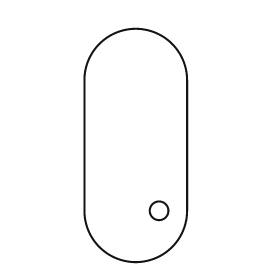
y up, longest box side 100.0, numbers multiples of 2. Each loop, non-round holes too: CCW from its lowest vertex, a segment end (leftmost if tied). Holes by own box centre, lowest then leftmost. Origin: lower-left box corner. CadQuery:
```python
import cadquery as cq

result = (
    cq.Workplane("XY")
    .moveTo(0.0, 22.0)
    .threePointArc((22.0, 0.0), (44.0, 22.0))
    .lineTo(44.0, 78.0)
    .threePointArc((22.0, 100.0), (0.0, 78.0))
    .close()
    .moveTo(32.0, 22.0)
    .circle(4.0)
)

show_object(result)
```